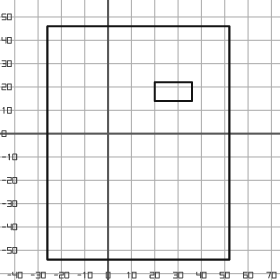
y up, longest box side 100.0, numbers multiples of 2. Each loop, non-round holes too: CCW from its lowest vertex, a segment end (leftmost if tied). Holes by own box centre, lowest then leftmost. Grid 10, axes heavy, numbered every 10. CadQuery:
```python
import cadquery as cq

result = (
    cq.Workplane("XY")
    .moveTo(-26.0, -54.0)
    .lineTo(52.0, -54.0)
    .lineTo(52.0, 46.0)
    .lineTo(-26.0, 46.0)
    .close()
    .moveTo(20.0, 14.0)
    .lineTo(36.0, 14.0)
    .lineTo(36.0, 22.0)
    .lineTo(20.0, 22.0)
    .close()
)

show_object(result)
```